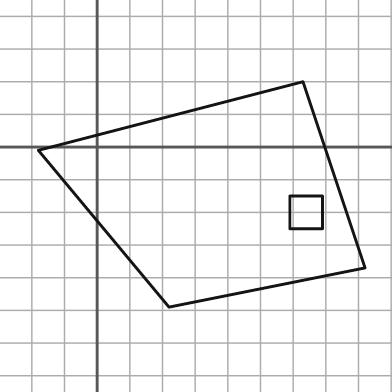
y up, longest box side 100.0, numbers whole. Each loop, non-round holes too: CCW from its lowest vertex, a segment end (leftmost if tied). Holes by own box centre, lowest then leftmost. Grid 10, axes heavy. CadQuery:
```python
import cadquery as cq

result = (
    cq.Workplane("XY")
    .moveTo(22.0, -49.0)
    .lineTo(82.0, -37.0)
    .lineTo(63.0, 20.0)
    .lineTo(-18.0, -1.0)
    .close()
    .moveTo(59.0, -25.0)
    .lineTo(69.0, -25.0)
    .lineTo(69.0, -15.0)
    .lineTo(59.0, -15.0)
    .close()
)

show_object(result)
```